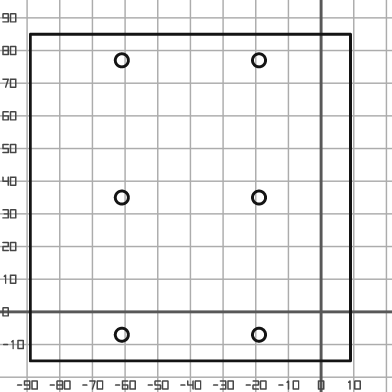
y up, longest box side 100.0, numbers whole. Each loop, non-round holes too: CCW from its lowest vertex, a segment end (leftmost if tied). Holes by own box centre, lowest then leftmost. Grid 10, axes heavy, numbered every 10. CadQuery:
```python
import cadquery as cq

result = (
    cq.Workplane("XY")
    .moveTo(-89.0, -15.0)
    .lineTo(9.0, -15.0)
    .lineTo(9.0, 85.0)
    .lineTo(-89.0, 85.0)
    .close()
    .moveTo(-61.0, -7.0)
    .circle(2.0)
    .moveTo(-19.0, -7.0)
    .circle(2.0)
    .moveTo(-61.0, 35.0)
    .circle(2.0)
    .moveTo(-19.0, 35.0)
    .circle(2.0)
    .moveTo(-61.0, 77.0)
    .circle(2.0)
    .moveTo(-19.0, 77.0)
    .circle(2.0)
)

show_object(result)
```